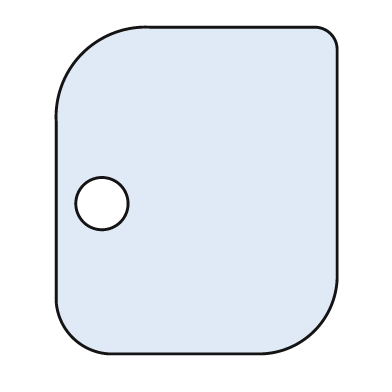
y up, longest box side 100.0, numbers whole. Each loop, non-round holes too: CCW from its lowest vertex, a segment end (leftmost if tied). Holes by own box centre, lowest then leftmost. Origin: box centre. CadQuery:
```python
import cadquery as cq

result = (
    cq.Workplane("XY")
    .moveTo(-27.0, -50.0)
    .lineTo(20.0, -50.0)
    .threePointArc((36.0, -43.0), (43.0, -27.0))
    .lineTo(43.0, 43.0)
    .threePointArc((41.0, 48.0), (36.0, 50.0))
    .lineTo(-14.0, 50.0)
    .threePointArc((-35.0, 42.0), (-43.0, 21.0))
    .lineTo(-43.0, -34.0)
    .threePointArc((-38.0, -45.0), (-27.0, -50.0))
    .close()
    .moveTo(-29.0, -4.0)
    .circle(8.0)
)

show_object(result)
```